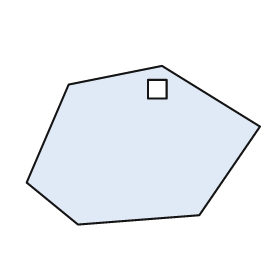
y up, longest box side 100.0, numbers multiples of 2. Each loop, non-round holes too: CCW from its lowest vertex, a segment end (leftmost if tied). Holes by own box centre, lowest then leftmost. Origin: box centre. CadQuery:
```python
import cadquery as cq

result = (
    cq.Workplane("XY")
    .moveTo(-28.0, -34.0)
    .lineTo(24.0, -30.0)
    .lineTo(50.0, 8.0)
    .lineTo(8.0, 34.0)
    .lineTo(-32.0, 26.0)
    .lineTo(-50.0, -16.0)
    .close()
    .moveTo(2.0, 20.0)
    .lineTo(10.0, 20.0)
    .lineTo(10.0, 28.0)
    .lineTo(2.0, 28.0)
    .close()
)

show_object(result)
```